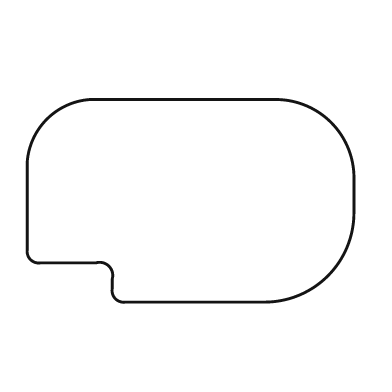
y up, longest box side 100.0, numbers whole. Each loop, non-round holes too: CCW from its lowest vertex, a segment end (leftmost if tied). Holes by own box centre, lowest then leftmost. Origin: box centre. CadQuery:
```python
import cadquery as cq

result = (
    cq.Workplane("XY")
    .moveTo(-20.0, -31.0)
    .lineTo(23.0, -31.0)
    .threePointArc((42.0, -23.0), (50.0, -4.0))
    .lineTo(50.0, 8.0)
    .threePointArc((43.0, 24.0), (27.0, 31.0))
    .lineTo(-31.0, 31.0)
    .threePointArc((-44.0, 25.0), (-50.0, 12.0))
    .lineTo(-50.0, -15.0)
    .threePointArc((-49.0, -18.0), (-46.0, -19.0))
    .lineTo(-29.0, -19.0)
    .threePointArc((-25.0, -20.0), (-24.0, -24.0))
    .lineTo(-24.0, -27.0)
    .threePointArc((-23.0, -30.0), (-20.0, -31.0))
    .close()
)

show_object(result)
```